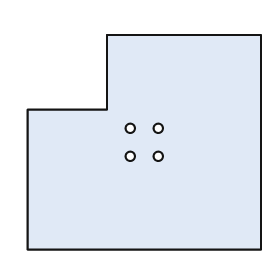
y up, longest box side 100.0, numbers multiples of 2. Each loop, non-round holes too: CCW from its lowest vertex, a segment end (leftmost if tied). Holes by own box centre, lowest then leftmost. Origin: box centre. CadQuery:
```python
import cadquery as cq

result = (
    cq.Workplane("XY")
    .moveTo(-50.0, -46.0)
    .lineTo(50.0, -46.0)
    .lineTo(50.0, 46.0)
    .lineTo(-16.0, 46.0)
    .lineTo(-16.0, 14.0)
    .lineTo(-50.0, 14.0)
    .close()
    .moveTo(-6.0, -6.0)
    .circle(2.0)
    .moveTo(6.0, -6.0)
    .circle(2.0)
    .moveTo(-6.0, 6.0)
    .circle(2.0)
    .moveTo(6.0, 6.0)
    .circle(2.0)
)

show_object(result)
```